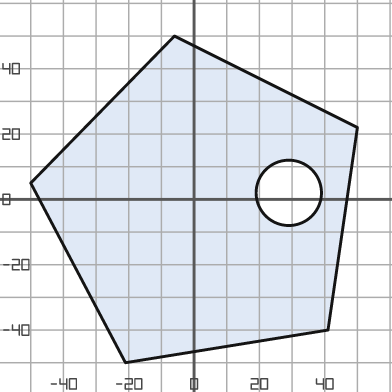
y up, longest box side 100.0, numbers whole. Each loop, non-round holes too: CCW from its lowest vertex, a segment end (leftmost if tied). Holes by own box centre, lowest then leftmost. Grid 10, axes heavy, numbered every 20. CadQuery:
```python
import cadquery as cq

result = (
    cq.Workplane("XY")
    .moveTo(-21.0, -50.0)
    .lineTo(41.0, -40.0)
    .lineTo(50.0, 22.0)
    .lineTo(-6.0, 50.0)
    .lineTo(-50.0, 5.0)
    .close()
    .moveTo(29.0, 2.0)
    .circle(10.0)
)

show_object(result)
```